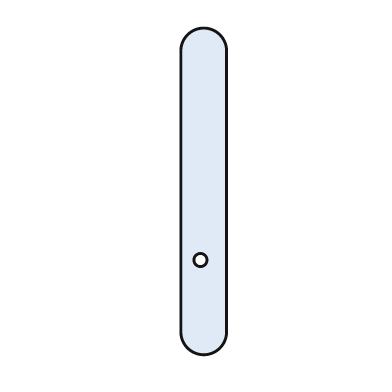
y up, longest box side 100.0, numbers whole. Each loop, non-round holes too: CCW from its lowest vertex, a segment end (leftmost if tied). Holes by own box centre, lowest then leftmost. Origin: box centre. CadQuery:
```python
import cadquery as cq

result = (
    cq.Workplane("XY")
    .moveTo(-7.0, -43.0)
    .threePointArc((0.0, -50.0), (7.0, -43.0))
    .lineTo(7.0, 43.0)
    .threePointArc((0.0, 50.0), (-7.0, 43.0))
    .close()
    .moveTo(-1.0, -21.0)
    .circle(2.0)
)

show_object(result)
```